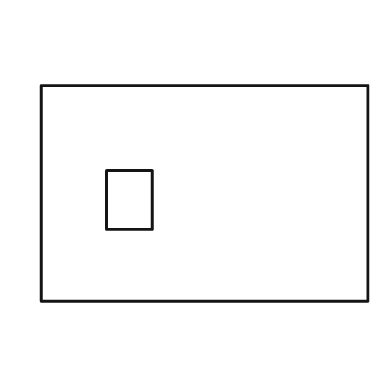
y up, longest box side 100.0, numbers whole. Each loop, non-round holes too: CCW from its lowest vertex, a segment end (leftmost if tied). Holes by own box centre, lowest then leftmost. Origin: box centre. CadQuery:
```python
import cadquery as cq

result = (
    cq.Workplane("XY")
    .moveTo(-50.0, -33.0)
    .lineTo(50.0, -33.0)
    .lineTo(50.0, 33.0)
    .lineTo(-50.0, 33.0)
    .close()
    .moveTo(-30.0, -11.0)
    .lineTo(-16.0, -11.0)
    .lineTo(-16.0, 7.0)
    .lineTo(-30.0, 7.0)
    .close()
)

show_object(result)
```